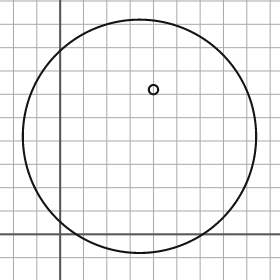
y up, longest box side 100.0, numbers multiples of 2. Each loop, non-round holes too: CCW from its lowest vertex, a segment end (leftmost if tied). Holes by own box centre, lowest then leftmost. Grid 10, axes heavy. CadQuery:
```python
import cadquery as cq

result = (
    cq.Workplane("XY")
    .moveTo(34.0, 42.0)
    .circle(50.0)
    .moveTo(40.0, 62.0)
    .circle(2.0)
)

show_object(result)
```